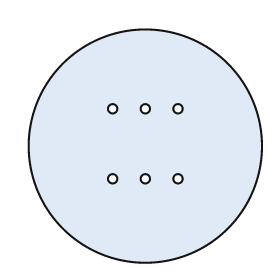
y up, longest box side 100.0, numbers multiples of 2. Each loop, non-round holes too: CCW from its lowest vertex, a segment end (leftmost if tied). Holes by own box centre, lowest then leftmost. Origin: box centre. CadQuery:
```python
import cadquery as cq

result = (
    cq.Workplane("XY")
    .moveTo(0.0, 0.0)
    .circle(50.0)
    .moveTo(-14.0, -14.0)
    .circle(2.0)
    .moveTo(0.0, -14.0)
    .circle(2.0)
    .moveTo(14.0, -14.0)
    .circle(2.0)
    .moveTo(-14.0, 16.0)
    .circle(2.0)
    .moveTo(0.0, 16.0)
    .circle(2.0)
    .moveTo(14.0, 16.0)
    .circle(2.0)
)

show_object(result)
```